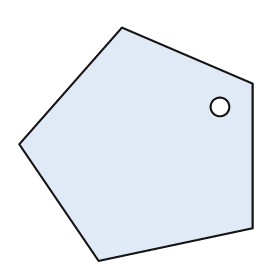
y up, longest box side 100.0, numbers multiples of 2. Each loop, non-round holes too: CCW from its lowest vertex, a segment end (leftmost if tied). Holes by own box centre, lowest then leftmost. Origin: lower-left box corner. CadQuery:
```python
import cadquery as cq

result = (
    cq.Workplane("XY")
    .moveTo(34.0, 0.0)
    .lineTo(100.0, 14.0)
    .lineTo(100.0, 76.0)
    .lineTo(44.0, 100.0)
    .lineTo(0.0, 50.0)
    .close()
    .moveTo(86.0, 66.0)
    .circle(4.0)
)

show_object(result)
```